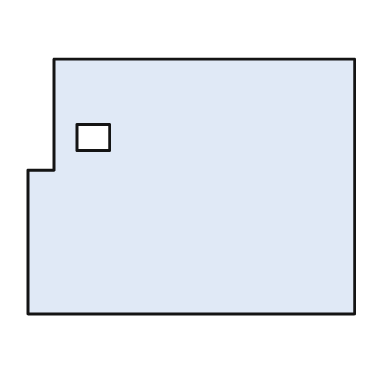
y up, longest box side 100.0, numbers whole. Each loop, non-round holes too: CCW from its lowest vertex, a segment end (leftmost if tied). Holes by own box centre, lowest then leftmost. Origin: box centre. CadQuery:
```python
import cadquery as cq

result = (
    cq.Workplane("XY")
    .moveTo(-50.0, -39.0)
    .lineTo(50.0, -39.0)
    .lineTo(50.0, 39.0)
    .lineTo(-42.0, 39.0)
    .lineTo(-42.0, 5.0)
    .lineTo(-50.0, 5.0)
    .close()
    .moveTo(-35.0, 11.0)
    .lineTo(-25.0, 11.0)
    .lineTo(-25.0, 19.0)
    .lineTo(-35.0, 19.0)
    .close()
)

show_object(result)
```